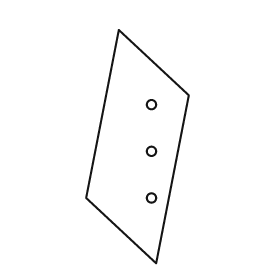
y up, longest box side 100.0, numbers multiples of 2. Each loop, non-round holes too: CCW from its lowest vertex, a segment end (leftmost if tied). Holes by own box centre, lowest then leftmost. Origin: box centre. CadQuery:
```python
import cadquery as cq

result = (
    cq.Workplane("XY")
    .moveTo(8.0, -50.0)
    .lineTo(22.0, 22.0)
    .lineTo(-8.0, 50.0)
    .lineTo(-22.0, -22.0)
    .close()
    .moveTo(6.0, -22.0)
    .circle(2.0)
    .moveTo(6.0, -2.0)
    .circle(2.0)
    .moveTo(6.0, 18.0)
    .circle(2.0)
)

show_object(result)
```